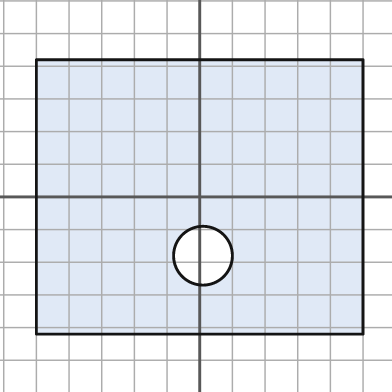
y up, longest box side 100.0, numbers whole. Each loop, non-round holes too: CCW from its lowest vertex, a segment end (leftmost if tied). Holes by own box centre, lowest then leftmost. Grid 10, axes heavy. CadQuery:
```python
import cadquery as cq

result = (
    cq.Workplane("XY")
    .moveTo(-50.0, -42.0)
    .lineTo(50.0, -42.0)
    .lineTo(50.0, 42.0)
    .lineTo(-50.0, 42.0)
    .close()
    .moveTo(1.0, -18.0)
    .circle(9.0)
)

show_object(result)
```